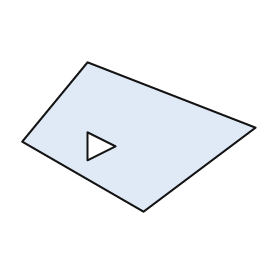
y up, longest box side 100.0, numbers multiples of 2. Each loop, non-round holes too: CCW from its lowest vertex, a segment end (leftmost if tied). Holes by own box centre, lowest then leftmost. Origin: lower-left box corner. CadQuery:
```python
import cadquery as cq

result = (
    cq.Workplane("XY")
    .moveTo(52.0, 0.0)
    .lineTo(100.0, 36.0)
    .lineTo(28.0, 64.0)
    .lineTo(0.0, 30.0)
    .close()
    .moveTo(28.0, 22.0)
    .lineTo(40.0, 28.0)
    .lineTo(28.0, 34.0)
    .close()
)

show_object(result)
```